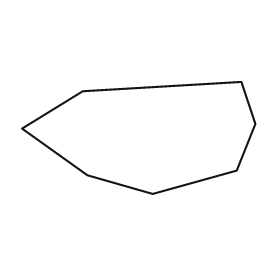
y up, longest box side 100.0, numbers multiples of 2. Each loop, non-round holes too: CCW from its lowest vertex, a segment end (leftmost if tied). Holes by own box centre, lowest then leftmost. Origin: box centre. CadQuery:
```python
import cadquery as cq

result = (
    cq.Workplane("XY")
    .moveTo(6.0, -24.0)
    .lineTo(42.0, -14.0)
    .lineTo(50.0, 6.0)
    .lineTo(44.0, 24.0)
    .lineTo(-24.0, 20.0)
    .lineTo(-50.0, 4.0)
    .lineTo(-22.0, -16.0)
    .close()
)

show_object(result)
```